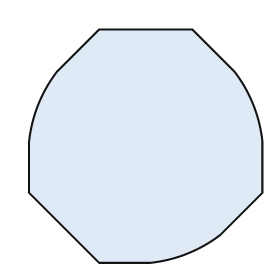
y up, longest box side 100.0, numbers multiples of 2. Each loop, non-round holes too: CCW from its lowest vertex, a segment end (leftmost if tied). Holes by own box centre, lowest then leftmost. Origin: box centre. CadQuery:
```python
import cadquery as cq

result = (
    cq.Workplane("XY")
    .moveTo(-20.0, -50.0)
    .lineTo(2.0, -50.0)
    .threePointArc((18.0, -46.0), (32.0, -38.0))
    .lineTo(50.0, -20.0)
    .lineTo(50.0, 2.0)
    .threePointArc((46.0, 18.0), (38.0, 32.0))
    .lineTo(20.0, 50.0)
    .lineTo(-20.0, 50.0)
    .lineTo(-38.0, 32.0)
    .threePointArc((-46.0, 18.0), (-50.0, 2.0))
    .lineTo(-50.0, -20.0)
    .close()
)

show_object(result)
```